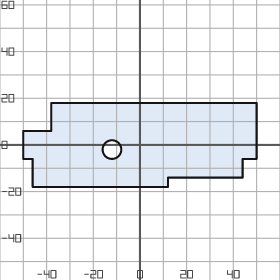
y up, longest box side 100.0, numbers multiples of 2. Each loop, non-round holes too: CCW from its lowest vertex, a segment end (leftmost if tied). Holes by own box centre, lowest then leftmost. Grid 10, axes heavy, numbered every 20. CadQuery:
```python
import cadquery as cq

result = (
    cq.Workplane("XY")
    .moveTo(-46.0, -18.0)
    .lineTo(12.0, -18.0)
    .lineTo(12.0, -14.0)
    .lineTo(44.0, -14.0)
    .lineTo(44.0, -6.0)
    .lineTo(50.0, -6.0)
    .lineTo(50.0, 18.0)
    .lineTo(-38.0, 18.0)
    .lineTo(-38.0, 6.0)
    .lineTo(-50.0, 6.0)
    .lineTo(-50.0, -6.0)
    .lineTo(-46.0, -6.0)
    .close()
    .moveTo(-12.0, -2.0)
    .circle(4.0)
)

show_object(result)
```